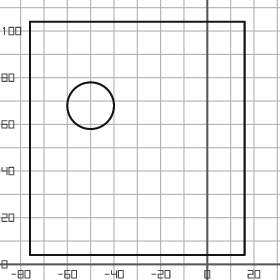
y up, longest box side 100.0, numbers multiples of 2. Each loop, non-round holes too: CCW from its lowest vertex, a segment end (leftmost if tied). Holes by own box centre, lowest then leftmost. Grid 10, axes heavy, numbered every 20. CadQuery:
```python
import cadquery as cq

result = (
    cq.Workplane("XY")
    .moveTo(-76.0, 4.0)
    .lineTo(16.0, 4.0)
    .lineTo(16.0, 104.0)
    .lineTo(-76.0, 104.0)
    .close()
    .moveTo(-50.0, 68.0)
    .circle(10.0)
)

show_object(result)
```